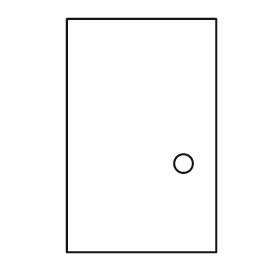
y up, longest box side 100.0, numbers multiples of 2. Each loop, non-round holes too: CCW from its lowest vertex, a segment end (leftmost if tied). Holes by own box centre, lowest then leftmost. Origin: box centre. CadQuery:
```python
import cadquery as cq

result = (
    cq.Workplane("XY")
    .moveTo(-32.0, -50.0)
    .lineTo(32.0, -50.0)
    .lineTo(32.0, 50.0)
    .lineTo(-32.0, 50.0)
    .close()
    .moveTo(18.0, -12.0)
    .circle(4.0)
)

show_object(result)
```